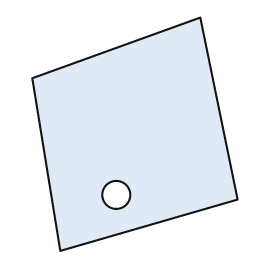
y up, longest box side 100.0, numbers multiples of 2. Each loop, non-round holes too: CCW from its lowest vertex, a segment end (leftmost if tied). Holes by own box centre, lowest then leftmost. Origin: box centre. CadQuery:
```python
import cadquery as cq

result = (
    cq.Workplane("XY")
    .moveTo(-32.0, -50.0)
    .lineTo(44.0, -28.0)
    .lineTo(28.0, 50.0)
    .lineTo(-44.0, 24.0)
    .close()
    .moveTo(-8.0, -26.0)
    .circle(6.0)
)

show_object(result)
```